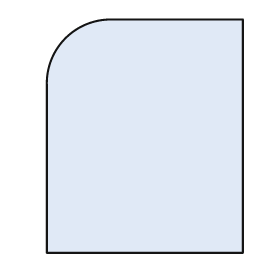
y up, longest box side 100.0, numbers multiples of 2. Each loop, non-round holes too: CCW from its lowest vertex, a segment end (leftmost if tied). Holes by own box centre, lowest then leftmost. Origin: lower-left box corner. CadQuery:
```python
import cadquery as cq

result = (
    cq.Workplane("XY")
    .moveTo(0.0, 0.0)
    .lineTo(84.0, 0.0)
    .lineTo(84.0, 100.0)
    .lineTo(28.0, 100.0)
    .threePointArc((8.0, 92.0), (0.0, 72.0))
    .close()
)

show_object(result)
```